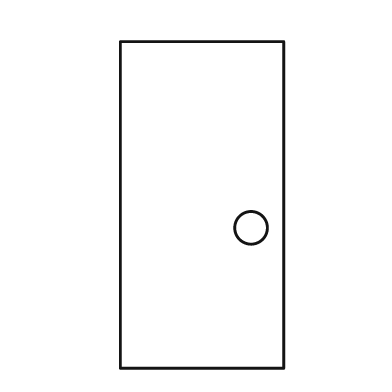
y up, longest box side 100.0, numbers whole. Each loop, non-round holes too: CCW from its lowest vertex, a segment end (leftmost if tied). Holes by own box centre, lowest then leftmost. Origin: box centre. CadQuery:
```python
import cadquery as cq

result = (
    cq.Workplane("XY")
    .moveTo(-25.0, -50.0)
    .lineTo(25.0, -50.0)
    .lineTo(25.0, 50.0)
    .lineTo(-25.0, 50.0)
    .close()
    .moveTo(15.0, -7.0)
    .circle(5.0)
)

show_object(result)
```